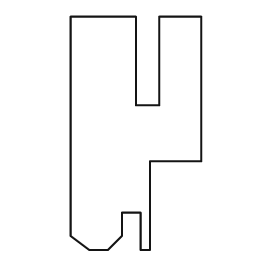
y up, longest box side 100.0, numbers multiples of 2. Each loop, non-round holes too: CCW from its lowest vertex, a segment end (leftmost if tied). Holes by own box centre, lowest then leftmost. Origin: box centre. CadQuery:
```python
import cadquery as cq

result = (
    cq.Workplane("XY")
    .moveTo(-20.0, -50.0)
    .lineTo(-12.0, -50.0)
    .lineTo(-6.0, -44.0)
    .lineTo(-6.0, -34.0)
    .lineTo(2.0, -34.0)
    .lineTo(2.0, -50.0)
    .lineTo(6.0, -50.0)
    .lineTo(6.0, -12.0)
    .lineTo(28.0, -12.0)
    .lineTo(28.0, 50.0)
    .lineTo(10.0, 50.0)
    .lineTo(10.0, 12.0)
    .lineTo(0.0, 12.0)
    .lineTo(0.0, 50.0)
    .lineTo(-28.0, 50.0)
    .lineTo(-28.0, -44.0)
    .close()
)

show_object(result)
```